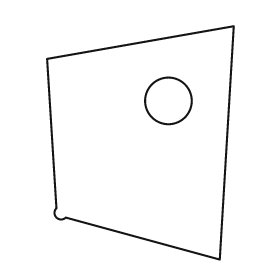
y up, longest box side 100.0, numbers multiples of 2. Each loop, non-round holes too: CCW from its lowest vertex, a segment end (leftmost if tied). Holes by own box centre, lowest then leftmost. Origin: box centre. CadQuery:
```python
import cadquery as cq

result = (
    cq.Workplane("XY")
    .moveTo(34.0, -50.0)
    .lineTo(40.0, 50.0)
    .lineTo(-40.0, 36.0)
    .lineTo(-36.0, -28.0)
    .threePointArc((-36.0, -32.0), (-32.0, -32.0))
    .close()
    .moveTo(12.0, 18.0)
    .circle(10.0)
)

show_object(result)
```